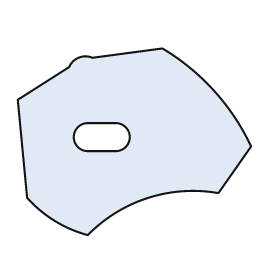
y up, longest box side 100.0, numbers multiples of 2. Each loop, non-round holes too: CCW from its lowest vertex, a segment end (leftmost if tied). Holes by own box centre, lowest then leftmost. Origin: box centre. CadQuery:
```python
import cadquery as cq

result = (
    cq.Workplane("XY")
    .moveTo(-20.0, -40.0)
    .threePointArc((6.0, -24.0), (36.0, -22.0))
    .lineTo(50.0, -2.0)
    .threePointArc((34.0, 22.0), (12.0, 40.0))
    .lineTo(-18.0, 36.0)
    .threePointArc((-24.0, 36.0), (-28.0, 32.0))
    .lineTo(-50.0, 18.0)
    .lineTo(-46.0, -24.0)
    .threePointArc((-34.0, -34.0), (-20.0, -40.0))
    .close()
    .moveTo(-20.0, -4.0)
    .lineTo(-8.0, -4.0)
    .threePointArc((-2.0, 2.0), (-8.0, 8.0))
    .lineTo(-20.0, 8.0)
    .threePointArc((-26.0, 2.0), (-20.0, -4.0))
    .close()
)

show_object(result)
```